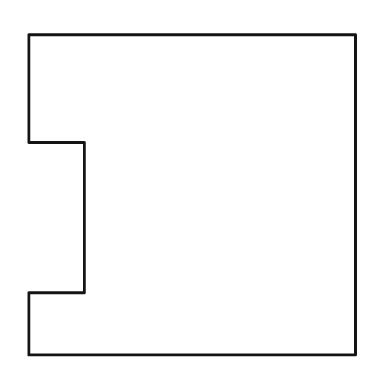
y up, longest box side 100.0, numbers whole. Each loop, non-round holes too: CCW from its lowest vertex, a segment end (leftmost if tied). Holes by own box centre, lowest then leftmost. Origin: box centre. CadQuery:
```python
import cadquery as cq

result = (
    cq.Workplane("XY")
    .moveTo(-50.0, -49.0)
    .lineTo(50.0, -49.0)
    .lineTo(50.0, 49.0)
    .lineTo(-50.0, 49.0)
    .lineTo(-50.0, 16.0)
    .lineTo(-33.0, 16.0)
    .lineTo(-33.0, -30.0)
    .lineTo(-50.0, -30.0)
    .close()
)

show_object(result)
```